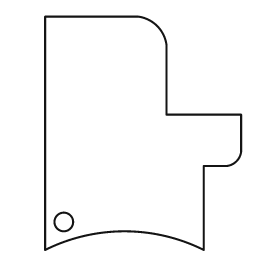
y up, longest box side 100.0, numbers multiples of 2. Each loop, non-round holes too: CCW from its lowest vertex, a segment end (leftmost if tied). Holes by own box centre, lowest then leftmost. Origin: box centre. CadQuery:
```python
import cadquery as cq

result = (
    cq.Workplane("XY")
    .moveTo(-42.0, -50.0)
    .threePointArc((-8.0, -42.0), (26.0, -50.0))
    .lineTo(26.0, -14.0)
    .lineTo(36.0, -14.0)
    .threePointArc((40.0, -12.0), (42.0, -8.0))
    .lineTo(42.0, 8.0)
    .lineTo(10.0, 8.0)
    .lineTo(10.0, 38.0)
    .threePointArc((6.0, 46.0), (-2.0, 50.0))
    .lineTo(-42.0, 50.0)
    .close()
    .moveTo(-34.0, -38.0)
    .circle(4.0)
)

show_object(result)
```